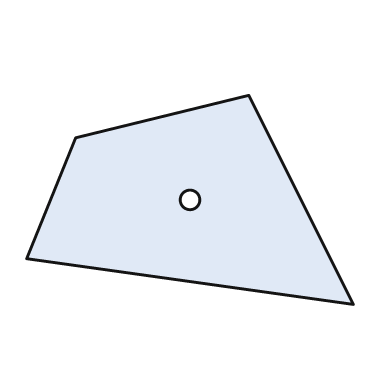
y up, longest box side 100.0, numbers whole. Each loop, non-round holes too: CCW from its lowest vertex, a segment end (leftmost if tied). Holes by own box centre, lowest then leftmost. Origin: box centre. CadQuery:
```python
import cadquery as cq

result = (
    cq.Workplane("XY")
    .moveTo(50.0, -32.0)
    .lineTo(18.0, 32.0)
    .lineTo(-35.0, 19.0)
    .lineTo(-50.0, -18.0)
    .close()
    .moveTo(0.0, 0.0)
    .circle(3.0)
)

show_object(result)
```